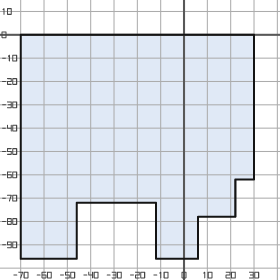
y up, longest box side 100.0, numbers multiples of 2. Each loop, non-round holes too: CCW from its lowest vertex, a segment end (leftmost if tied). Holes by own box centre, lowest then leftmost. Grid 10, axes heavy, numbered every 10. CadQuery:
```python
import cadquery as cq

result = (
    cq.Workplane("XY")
    .moveTo(-70.0, -96.0)
    .lineTo(-46.0, -96.0)
    .lineTo(-46.0, -72.0)
    .lineTo(-12.0, -72.0)
    .lineTo(-12.0, -96.0)
    .lineTo(6.0, -96.0)
    .lineTo(6.0, -78.0)
    .lineTo(22.0, -78.0)
    .lineTo(22.0, -62.0)
    .lineTo(30.0, -62.0)
    .lineTo(30.0, 0.0)
    .lineTo(-70.0, 0.0)
    .close()
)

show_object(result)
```